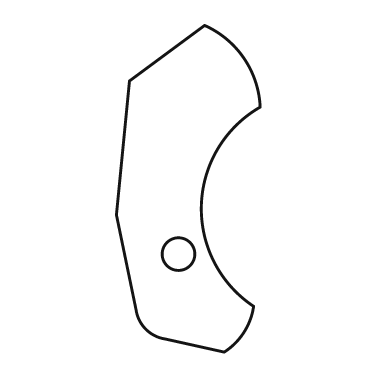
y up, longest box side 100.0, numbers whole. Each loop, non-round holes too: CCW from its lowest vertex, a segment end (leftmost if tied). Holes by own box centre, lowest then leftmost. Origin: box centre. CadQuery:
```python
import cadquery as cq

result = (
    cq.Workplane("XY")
    .moveTo(11.0, -50.0)
    .threePointArc((17.0, -44.0), (20.0, -36.0))
    .threePointArc((4.0, -5.0), (22.0, 25.0))
    .threePointArc((17.0, 40.0), (5.0, 50.0))
    .lineTo(-18.0, 33.0)
    .lineTo(-22.0, -8.0)
    .lineTo(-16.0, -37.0)
    .threePointArc((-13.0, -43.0), (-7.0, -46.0))
    .close()
    .moveTo(-3.0, -20.0)
    .circle(5.0)
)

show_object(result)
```